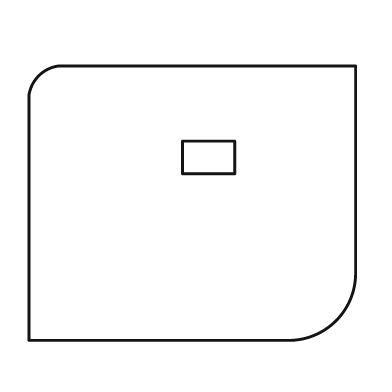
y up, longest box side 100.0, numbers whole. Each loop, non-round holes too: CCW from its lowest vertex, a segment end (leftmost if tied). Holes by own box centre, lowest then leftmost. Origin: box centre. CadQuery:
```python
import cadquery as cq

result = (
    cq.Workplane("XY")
    .moveTo(-50.0, -42.0)
    .lineTo(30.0, -42.0)
    .threePointArc((44.0, -36.0), (50.0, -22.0))
    .lineTo(50.0, 42.0)
    .lineTo(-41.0, 42.0)
    .threePointArc((-47.0, 39.0), (-50.0, 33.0))
    .close()
    .moveTo(-3.0, 9.0)
    .lineTo(13.0, 9.0)
    .lineTo(13.0, 19.0)
    .lineTo(-3.0, 19.0)
    .close()
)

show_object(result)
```